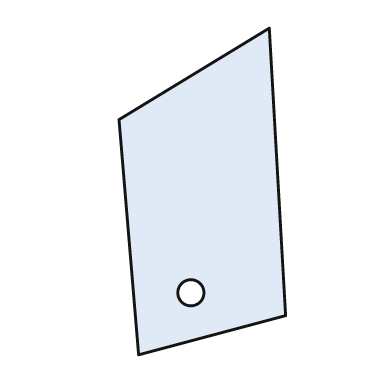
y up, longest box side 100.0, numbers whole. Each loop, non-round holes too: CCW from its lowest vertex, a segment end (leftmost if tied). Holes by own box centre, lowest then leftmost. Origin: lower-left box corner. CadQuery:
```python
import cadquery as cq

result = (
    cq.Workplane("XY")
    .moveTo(6.0, 0.0)
    .lineTo(51.0, 12.0)
    .lineTo(46.0, 100.0)
    .lineTo(0.0, 72.0)
    .close()
    .moveTo(22.0, 19.0)
    .circle(4.0)
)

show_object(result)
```